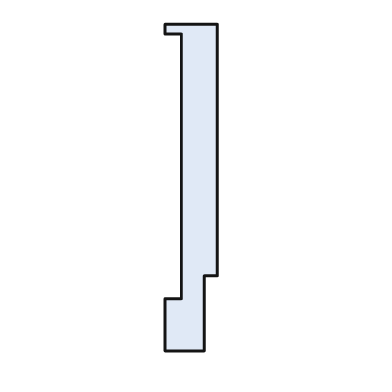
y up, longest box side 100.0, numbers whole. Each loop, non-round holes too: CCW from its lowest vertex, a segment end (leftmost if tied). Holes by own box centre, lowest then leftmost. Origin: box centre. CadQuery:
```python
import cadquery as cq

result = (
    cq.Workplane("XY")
    .moveTo(-8.0, -50.0)
    .lineTo(4.0, -50.0)
    .lineTo(4.0, -27.0)
    .lineTo(8.0, -27.0)
    .lineTo(8.0, 50.0)
    .lineTo(-8.0, 50.0)
    .lineTo(-8.0, 47.0)
    .lineTo(-3.0, 47.0)
    .lineTo(-3.0, -34.0)
    .lineTo(-8.0, -34.0)
    .close()
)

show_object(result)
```